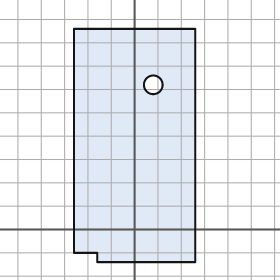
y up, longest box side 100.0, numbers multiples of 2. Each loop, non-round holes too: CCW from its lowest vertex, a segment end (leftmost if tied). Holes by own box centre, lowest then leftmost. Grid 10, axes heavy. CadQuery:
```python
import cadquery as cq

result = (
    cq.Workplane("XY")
    .moveTo(-16.0, -14.0)
    .lineTo(26.0, -14.0)
    .lineTo(26.0, 86.0)
    .lineTo(-26.0, 86.0)
    .lineTo(-26.0, -10.0)
    .lineTo(-16.0, -10.0)
    .close()
    .moveTo(8.0, 62.0)
    .circle(4.0)
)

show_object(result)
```